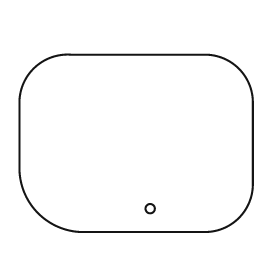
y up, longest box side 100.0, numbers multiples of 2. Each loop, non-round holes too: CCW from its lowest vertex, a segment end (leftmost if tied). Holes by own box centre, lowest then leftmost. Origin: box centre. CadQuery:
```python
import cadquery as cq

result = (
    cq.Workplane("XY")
    .moveTo(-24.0, -38.0)
    .lineTo(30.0, -38.0)
    .threePointArc((44.0, -32.0), (50.0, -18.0))
    .lineTo(50.0, 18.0)
    .threePointArc((44.0, 32.0), (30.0, 38.0))
    .lineTo(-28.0, 38.0)
    .threePointArc((-44.0, 32.0), (-50.0, 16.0))
    .lineTo(-50.0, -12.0)
    .threePointArc((-42.0, -30.0), (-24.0, -38.0))
    .close()
    .moveTo(6.0, -28.0)
    .circle(2.0)
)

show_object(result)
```